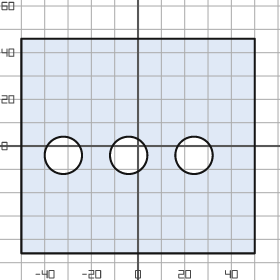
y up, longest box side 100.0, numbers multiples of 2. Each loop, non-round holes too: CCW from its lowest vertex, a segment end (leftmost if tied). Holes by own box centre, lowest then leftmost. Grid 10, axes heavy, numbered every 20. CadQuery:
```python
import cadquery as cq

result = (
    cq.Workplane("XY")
    .moveTo(-50.0, -46.0)
    .lineTo(50.0, -46.0)
    .lineTo(50.0, 46.0)
    .lineTo(-50.0, 46.0)
    .close()
    .moveTo(-32.0, -4.0)
    .circle(8.0)
    .moveTo(-4.0, -4.0)
    .circle(8.0)
    .moveTo(24.0, -4.0)
    .circle(8.0)
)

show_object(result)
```